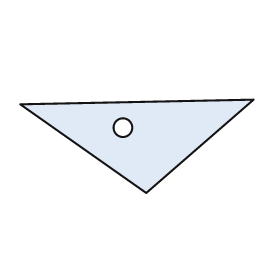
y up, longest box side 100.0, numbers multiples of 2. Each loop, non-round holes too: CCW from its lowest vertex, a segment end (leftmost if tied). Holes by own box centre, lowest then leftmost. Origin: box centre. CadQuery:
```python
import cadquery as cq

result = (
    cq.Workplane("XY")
    .moveTo(4.0, -20.0)
    .lineTo(50.0, 20.0)
    .lineTo(-50.0, 18.0)
    .close()
    .moveTo(-6.0, 8.0)
    .circle(4.0)
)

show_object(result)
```